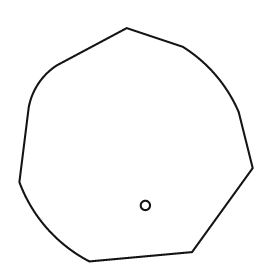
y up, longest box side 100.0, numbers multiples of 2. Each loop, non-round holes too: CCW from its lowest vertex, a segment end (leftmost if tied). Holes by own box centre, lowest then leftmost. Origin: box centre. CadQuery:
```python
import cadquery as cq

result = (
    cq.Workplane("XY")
    .moveTo(-20.0, -50.0)
    .lineTo(24.0, -46.0)
    .lineTo(50.0, -10.0)
    .lineTo(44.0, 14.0)
    .threePointArc((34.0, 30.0), (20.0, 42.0))
    .lineTo(-4.0, 50.0)
    .lineTo(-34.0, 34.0)
    .threePointArc((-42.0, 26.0), (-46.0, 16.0))
    .lineTo(-50.0, -16.0)
    .threePointArc((-38.0, -36.0), (-20.0, -50.0))
    .close()
    .moveTo(4.0, -26.0)
    .circle(2.0)
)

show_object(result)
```